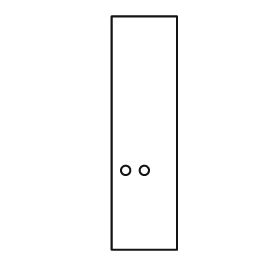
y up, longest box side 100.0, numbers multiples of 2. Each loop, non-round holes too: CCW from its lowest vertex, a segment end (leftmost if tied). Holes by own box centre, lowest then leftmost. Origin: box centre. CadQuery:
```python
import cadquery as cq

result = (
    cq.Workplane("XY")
    .moveTo(-14.0, -50.0)
    .lineTo(14.0, -50.0)
    .lineTo(14.0, 50.0)
    .lineTo(-14.0, 50.0)
    .close()
    .moveTo(-8.0, -16.0)
    .circle(2.0)
    .moveTo(0.0, -16.0)
    .circle(2.0)
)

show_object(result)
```